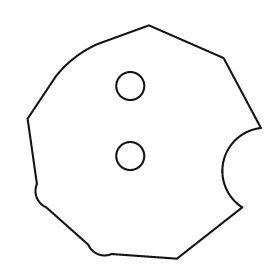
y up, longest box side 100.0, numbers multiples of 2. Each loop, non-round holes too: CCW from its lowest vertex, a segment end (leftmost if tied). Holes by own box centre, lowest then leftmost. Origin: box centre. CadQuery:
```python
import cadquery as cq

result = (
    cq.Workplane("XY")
    .moveTo(14.0, -50.0)
    .lineTo(42.0, -28.0)
    .threePointArc((34.0, -8.0), (50.0, 6.0))
    .lineTo(34.0, 36.0)
    .lineTo(2.0, 50.0)
    .lineTo(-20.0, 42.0)
    .threePointArc((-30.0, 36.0), (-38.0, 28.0))
    .lineTo(-50.0, 10.0)
    .lineTo(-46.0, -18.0)
    .threePointArc((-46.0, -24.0), (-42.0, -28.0))
    .lineTo(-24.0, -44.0)
    .threePointArc((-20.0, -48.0), (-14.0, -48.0))
    .close()
    .moveTo(-6.0, -6.0)
    .circle(6.0)
    .moveTo(-6.0, 24.0)
    .circle(6.0)
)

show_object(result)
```